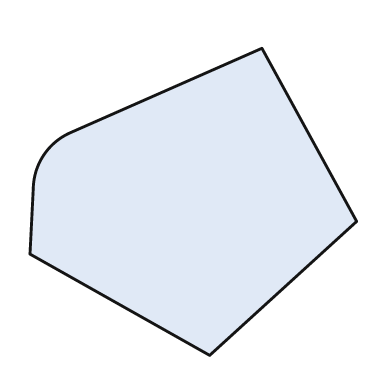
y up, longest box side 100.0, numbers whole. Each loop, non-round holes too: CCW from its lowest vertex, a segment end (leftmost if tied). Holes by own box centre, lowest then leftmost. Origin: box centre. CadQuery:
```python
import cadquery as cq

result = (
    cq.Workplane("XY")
    .moveTo(5.0, -47.0)
    .lineTo(50.0, -6.0)
    .lineTo(21.0, 47.0)
    .lineTo(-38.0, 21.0)
    .threePointArc((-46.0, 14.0), (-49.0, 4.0))
    .lineTo(-50.0, -16.0)
    .close()
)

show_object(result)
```